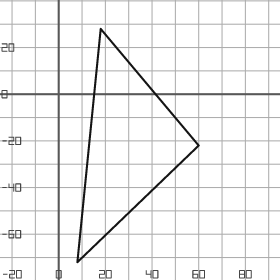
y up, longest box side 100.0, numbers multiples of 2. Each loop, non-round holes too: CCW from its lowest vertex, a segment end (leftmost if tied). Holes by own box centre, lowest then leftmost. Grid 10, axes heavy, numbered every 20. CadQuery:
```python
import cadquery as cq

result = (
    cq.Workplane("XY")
    .moveTo(8.0, -72.0)
    .lineTo(60.0, -22.0)
    .lineTo(18.0, 28.0)
    .close()
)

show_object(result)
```